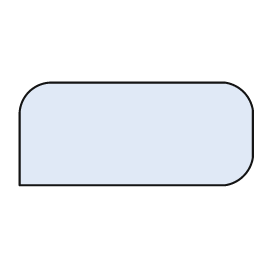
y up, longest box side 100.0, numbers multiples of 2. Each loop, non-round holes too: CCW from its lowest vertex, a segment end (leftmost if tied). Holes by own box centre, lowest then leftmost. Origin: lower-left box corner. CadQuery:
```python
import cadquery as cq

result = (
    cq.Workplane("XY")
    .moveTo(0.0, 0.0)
    .lineTo(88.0, 0.0)
    .threePointArc((96.0, 4.0), (100.0, 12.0))
    .lineTo(100.0, 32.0)
    .threePointArc((96.0, 40.0), (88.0, 44.0))
    .lineTo(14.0, 44.0)
    .threePointArc((4.0, 40.0), (0.0, 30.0))
    .close()
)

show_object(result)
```